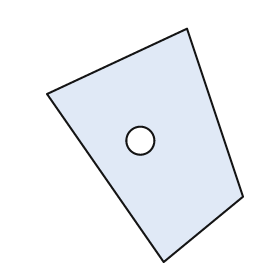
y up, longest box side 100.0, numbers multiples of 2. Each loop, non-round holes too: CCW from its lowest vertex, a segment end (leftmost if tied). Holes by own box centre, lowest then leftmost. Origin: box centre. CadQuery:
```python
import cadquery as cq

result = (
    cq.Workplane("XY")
    .moveTo(8.0, -50.0)
    .lineTo(42.0, -22.0)
    .lineTo(18.0, 50.0)
    .lineTo(-42.0, 22.0)
    .close()
    .moveTo(-2.0, 2.0)
    .circle(6.0)
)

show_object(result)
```